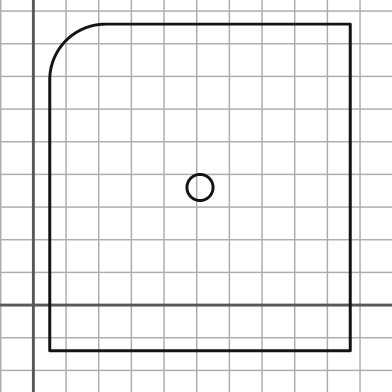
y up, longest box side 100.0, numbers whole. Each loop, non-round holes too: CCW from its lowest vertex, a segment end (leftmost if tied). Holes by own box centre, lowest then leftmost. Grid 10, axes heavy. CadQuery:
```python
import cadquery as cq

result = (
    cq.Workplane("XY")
    .moveTo(5.0, -14.0)
    .lineTo(97.0, -14.0)
    .lineTo(97.0, 86.0)
    .lineTo(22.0, 86.0)
    .threePointArc((10.0, 81.0), (5.0, 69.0))
    .close()
    .moveTo(51.0, 36.0)
    .circle(4.0)
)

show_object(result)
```